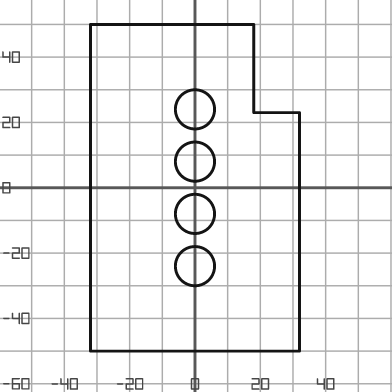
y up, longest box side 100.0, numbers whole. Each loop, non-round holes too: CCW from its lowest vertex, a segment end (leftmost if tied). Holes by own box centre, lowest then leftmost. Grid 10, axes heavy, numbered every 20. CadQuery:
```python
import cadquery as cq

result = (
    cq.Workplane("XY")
    .moveTo(-32.0, -50.0)
    .lineTo(32.0, -50.0)
    .lineTo(32.0, 23.0)
    .lineTo(18.0, 23.0)
    .lineTo(18.0, 50.0)
    .lineTo(-32.0, 50.0)
    .close()
    .moveTo(0.0, -24.0)
    .circle(6.0)
    .moveTo(0.0, -8.0)
    .circle(6.0)
    .moveTo(0.0, 8.0)
    .circle(6.0)
    .moveTo(0.0, 24.0)
    .circle(6.0)
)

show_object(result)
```